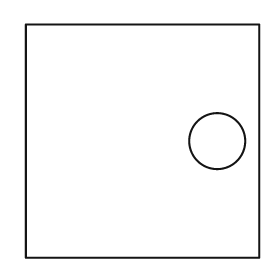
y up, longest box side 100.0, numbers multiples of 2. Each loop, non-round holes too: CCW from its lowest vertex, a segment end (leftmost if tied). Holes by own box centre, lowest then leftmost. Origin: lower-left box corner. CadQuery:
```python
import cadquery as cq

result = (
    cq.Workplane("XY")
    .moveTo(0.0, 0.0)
    .lineTo(100.0, 0.0)
    .lineTo(100.0, 100.0)
    .lineTo(0.0, 100.0)
    .close()
    .moveTo(82.0, 50.0)
    .circle(12.0)
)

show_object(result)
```